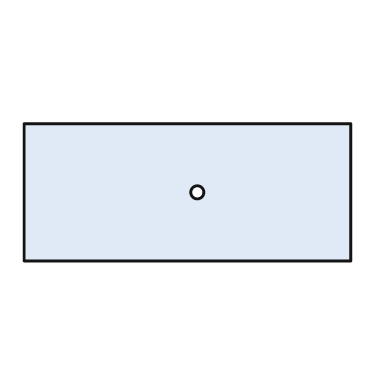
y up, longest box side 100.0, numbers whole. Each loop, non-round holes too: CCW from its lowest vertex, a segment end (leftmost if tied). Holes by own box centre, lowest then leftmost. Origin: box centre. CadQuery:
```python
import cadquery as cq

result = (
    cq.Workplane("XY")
    .moveTo(-50.0, -21.0)
    .lineTo(50.0, -21.0)
    .lineTo(50.0, 21.0)
    .lineTo(-50.0, 21.0)
    .close()
    .moveTo(3.0, 0.0)
    .circle(2.0)
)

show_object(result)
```